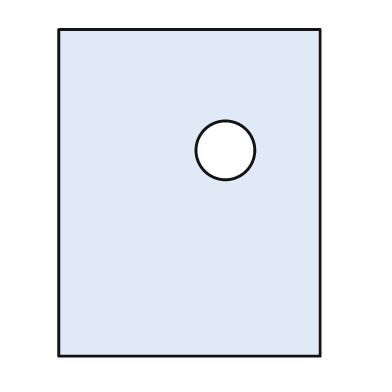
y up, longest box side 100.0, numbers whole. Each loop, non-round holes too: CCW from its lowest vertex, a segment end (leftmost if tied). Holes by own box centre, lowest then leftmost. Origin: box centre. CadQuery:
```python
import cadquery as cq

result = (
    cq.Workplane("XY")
    .moveTo(-40.0, -50.0)
    .lineTo(40.0, -50.0)
    .lineTo(40.0, 50.0)
    .lineTo(-40.0, 50.0)
    .close()
    .moveTo(11.0, 13.0)
    .circle(9.0)
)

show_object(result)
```